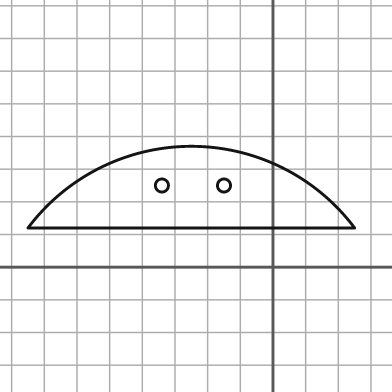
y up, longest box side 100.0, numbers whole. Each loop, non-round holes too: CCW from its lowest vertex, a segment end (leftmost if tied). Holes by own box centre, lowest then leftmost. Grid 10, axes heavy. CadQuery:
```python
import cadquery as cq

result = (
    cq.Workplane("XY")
    .moveTo(-75.0, 12.0)
    .lineTo(25.0, 12.0)
    .threePointArc((-25.0, 37.0), (-75.0, 12.0))
    .close()
    .moveTo(-34.0, 25.0)
    .circle(2.0)
    .moveTo(-15.0, 25.0)
    .circle(2.0)
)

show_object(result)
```